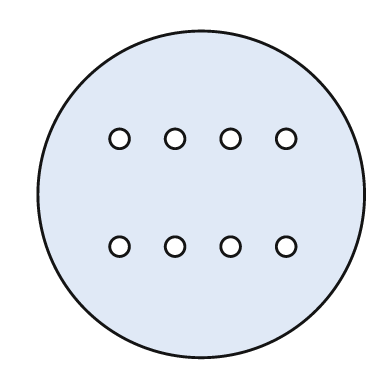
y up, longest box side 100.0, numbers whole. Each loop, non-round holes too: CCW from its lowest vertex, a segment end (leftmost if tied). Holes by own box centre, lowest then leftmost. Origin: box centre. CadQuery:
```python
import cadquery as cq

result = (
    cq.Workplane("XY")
    .moveTo(0.0, 0.0)
    .circle(50.0)
    .moveTo(-25.0, -16.0)
    .circle(3.0)
    .moveTo(-8.0, -16.0)
    .circle(3.0)
    .moveTo(9.0, -16.0)
    .circle(3.0)
    .moveTo(26.0, -16.0)
    .circle(3.0)
    .moveTo(-25.0, 17.0)
    .circle(3.0)
    .moveTo(-8.0, 17.0)
    .circle(3.0)
    .moveTo(9.0, 17.0)
    .circle(3.0)
    .moveTo(26.0, 17.0)
    .circle(3.0)
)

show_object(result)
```